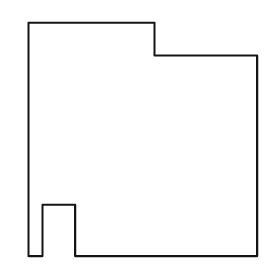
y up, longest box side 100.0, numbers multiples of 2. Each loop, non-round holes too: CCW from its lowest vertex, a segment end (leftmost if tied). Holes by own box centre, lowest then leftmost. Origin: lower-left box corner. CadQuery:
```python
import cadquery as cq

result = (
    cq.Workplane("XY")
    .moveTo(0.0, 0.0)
    .lineTo(6.0, 0.0)
    .lineTo(6.0, 22.0)
    .lineTo(20.0, 22.0)
    .lineTo(20.0, 0.0)
    .lineTo(98.0, 0.0)
    .lineTo(98.0, 86.0)
    .lineTo(54.0, 86.0)
    .lineTo(54.0, 100.0)
    .lineTo(0.0, 100.0)
    .close()
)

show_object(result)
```